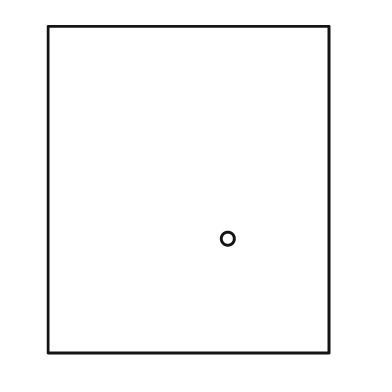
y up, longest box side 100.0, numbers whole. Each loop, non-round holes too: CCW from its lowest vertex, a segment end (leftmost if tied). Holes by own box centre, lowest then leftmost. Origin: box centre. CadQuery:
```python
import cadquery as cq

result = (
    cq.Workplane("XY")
    .moveTo(-43.0, -50.0)
    .lineTo(43.0, -50.0)
    .lineTo(43.0, 50.0)
    .lineTo(-43.0, 50.0)
    .close()
    .moveTo(12.0, -15.0)
    .circle(2.0)
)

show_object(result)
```